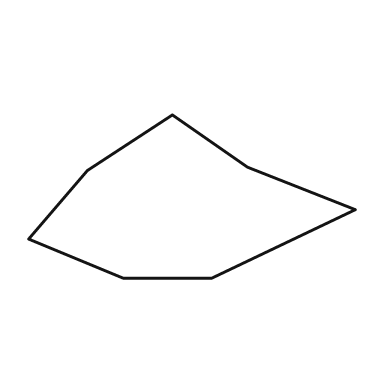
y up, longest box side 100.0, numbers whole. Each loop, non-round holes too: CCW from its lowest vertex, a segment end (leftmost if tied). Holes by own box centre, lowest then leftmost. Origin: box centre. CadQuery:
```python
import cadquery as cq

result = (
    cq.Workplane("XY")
    .moveTo(-21.0, -25.0)
    .lineTo(6.0, -25.0)
    .lineTo(50.0, -4.0)
    .lineTo(17.0, 9.0)
    .lineTo(-6.0, 25.0)
    .lineTo(-32.0, 8.0)
    .lineTo(-50.0, -13.0)
    .close()
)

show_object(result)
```